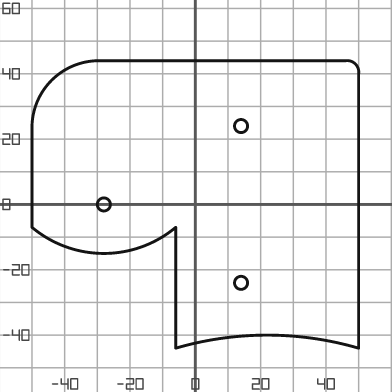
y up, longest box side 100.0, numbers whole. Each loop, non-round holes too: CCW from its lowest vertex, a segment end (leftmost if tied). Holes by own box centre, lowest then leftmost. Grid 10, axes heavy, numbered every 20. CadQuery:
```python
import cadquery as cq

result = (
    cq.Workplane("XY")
    .moveTo(-6.0, -44.0)
    .threePointArc((22.0, -40.0), (50.0, -44.0))
    .lineTo(50.0, 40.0)
    .threePointArc((49.0, 43.0), (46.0, 44.0))
    .lineTo(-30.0, 44.0)
    .threePointArc((-44.0, 38.0), (-50.0, 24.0))
    .lineTo(-50.0, -7.0)
    .threePointArc((-28.0, -15.0), (-6.0, -7.0))
    .close()
    .moveTo(14.0, -24.0)
    .circle(2.0)
    .moveTo(-28.0, 0.0)
    .circle(2.0)
    .moveTo(14.0, 24.0)
    .circle(2.0)
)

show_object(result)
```